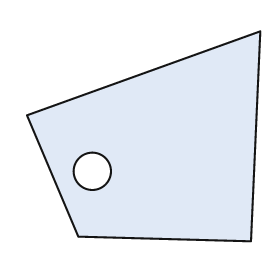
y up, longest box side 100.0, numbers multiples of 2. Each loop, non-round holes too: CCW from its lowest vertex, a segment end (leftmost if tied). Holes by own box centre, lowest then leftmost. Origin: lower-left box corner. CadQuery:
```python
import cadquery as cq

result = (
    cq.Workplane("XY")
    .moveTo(96.0, 0.0)
    .lineTo(100.0, 90.0)
    .lineTo(0.0, 54.0)
    .lineTo(22.0, 2.0)
    .close()
    .moveTo(28.0, 30.0)
    .circle(8.0)
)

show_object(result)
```